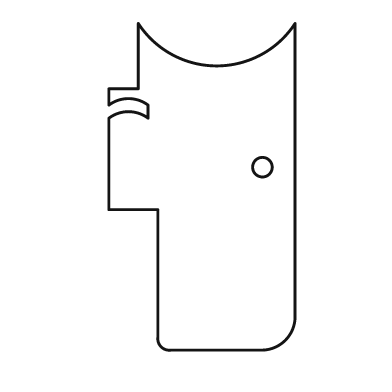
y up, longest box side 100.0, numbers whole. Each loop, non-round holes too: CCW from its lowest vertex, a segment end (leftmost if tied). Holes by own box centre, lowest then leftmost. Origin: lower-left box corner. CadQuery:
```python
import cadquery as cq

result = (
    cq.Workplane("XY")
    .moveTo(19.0, 0.0)
    .lineTo(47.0, 0.0)
    .threePointArc((54.0, 3.0), (57.0, 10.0))
    .lineTo(57.0, 100.0)
    .threePointArc((33.0, 87.0), (9.0, 100.0))
    .lineTo(9.0, 80.0)
    .lineTo(0.0, 80.0)
    .lineTo(0.0, 75.0)
    .threePointArc((6.0, 77.0), (12.0, 75.0))
    .lineTo(12.0, 71.0)
    .threePointArc((6.0, 73.0), (0.0, 71.0))
    .lineTo(0.0, 43.0)
    .lineTo(15.0, 43.0)
    .lineTo(15.0, 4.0)
    .threePointArc((16.0, 1.0), (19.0, 0.0))
    .close()
    .moveTo(47.0, 56.0)
    .circle(3.0)
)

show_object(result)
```